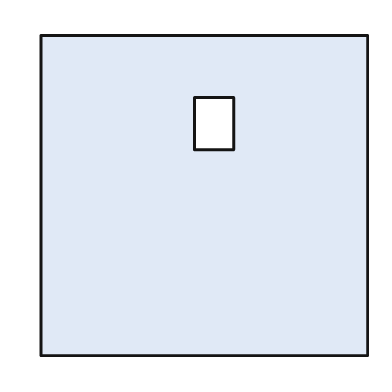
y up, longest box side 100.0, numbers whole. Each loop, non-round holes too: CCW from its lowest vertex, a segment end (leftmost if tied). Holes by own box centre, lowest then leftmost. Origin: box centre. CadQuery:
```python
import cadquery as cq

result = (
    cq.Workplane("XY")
    .moveTo(-50.0, -49.0)
    .lineTo(50.0, -49.0)
    .lineTo(50.0, 49.0)
    .lineTo(-50.0, 49.0)
    .close()
    .moveTo(-3.0, 14.0)
    .lineTo(9.0, 14.0)
    .lineTo(9.0, 30.0)
    .lineTo(-3.0, 30.0)
    .close()
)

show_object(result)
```